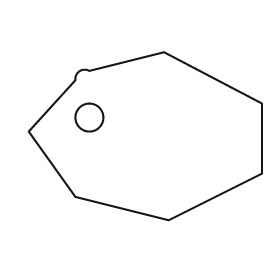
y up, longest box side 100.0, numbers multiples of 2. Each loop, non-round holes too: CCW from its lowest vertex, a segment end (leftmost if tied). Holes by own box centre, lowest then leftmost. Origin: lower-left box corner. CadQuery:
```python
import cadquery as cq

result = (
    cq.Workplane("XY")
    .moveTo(60.0, 0.0)
    .lineTo(100.0, 20.0)
    .lineTo(100.0, 50.0)
    .lineTo(58.0, 72.0)
    .lineTo(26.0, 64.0)
    .threePointArc((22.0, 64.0), (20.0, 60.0))
    .lineTo(0.0, 38.0)
    .lineTo(20.0, 10.0)
    .close()
    .moveTo(26.0, 44.0)
    .circle(6.0)
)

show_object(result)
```